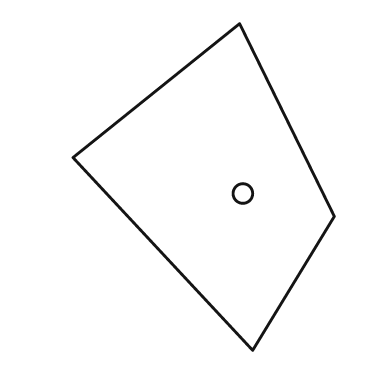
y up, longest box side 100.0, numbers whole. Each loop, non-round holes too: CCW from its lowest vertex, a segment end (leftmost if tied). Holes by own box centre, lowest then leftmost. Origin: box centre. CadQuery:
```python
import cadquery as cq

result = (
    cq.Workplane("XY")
    .moveTo(15.0, -50.0)
    .lineTo(40.0, -9.0)
    .lineTo(11.0, 50.0)
    .lineTo(-40.0, 9.0)
    .close()
    .moveTo(12.0, -2.0)
    .circle(3.0)
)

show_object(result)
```